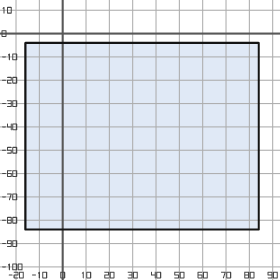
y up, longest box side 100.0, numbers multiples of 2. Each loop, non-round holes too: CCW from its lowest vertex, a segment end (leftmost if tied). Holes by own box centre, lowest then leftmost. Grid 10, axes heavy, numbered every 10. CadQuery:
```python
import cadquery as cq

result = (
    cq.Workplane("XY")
    .moveTo(-16.0, -84.0)
    .lineTo(84.0, -84.0)
    .lineTo(84.0, -4.0)
    .lineTo(-16.0, -4.0)
    .close()
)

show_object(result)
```